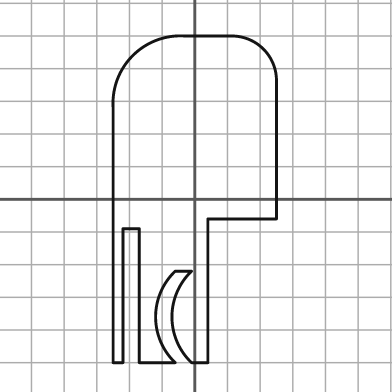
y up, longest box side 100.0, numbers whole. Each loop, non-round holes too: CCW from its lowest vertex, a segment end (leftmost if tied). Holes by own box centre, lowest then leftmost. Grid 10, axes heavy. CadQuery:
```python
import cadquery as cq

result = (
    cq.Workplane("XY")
    .moveTo(-25.0, -50.0)
    .lineTo(-22.0, -50.0)
    .lineTo(-22.0, -9.0)
    .lineTo(-17.0, -9.0)
    .lineTo(-17.0, -50.0)
    .lineTo(-6.0, -50.0)
    .threePointArc((-12.0, -36.0), (-6.0, -22.0))
    .lineTo(-1.0, -22.0)
    .threePointArc((-7.0, -36.0), (-1.0, -50.0))
    .lineTo(4.0, -50.0)
    .lineTo(4.0, -6.0)
    .lineTo(25.0, -6.0)
    .lineTo(25.0, 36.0)
    .threePointArc((21.0, 46.0), (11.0, 50.0))
    .lineTo(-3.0, 50.0)
    .threePointArc((-19.0, 44.0), (-25.0, 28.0))
    .close()
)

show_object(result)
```